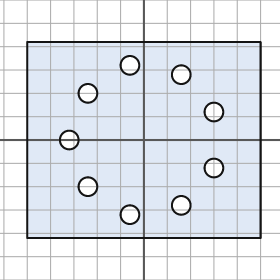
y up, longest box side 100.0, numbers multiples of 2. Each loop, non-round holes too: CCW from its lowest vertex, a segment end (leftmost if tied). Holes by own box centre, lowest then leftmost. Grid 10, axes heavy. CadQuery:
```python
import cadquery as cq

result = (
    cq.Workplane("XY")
    .moveTo(-50.0, -42.0)
    .lineTo(50.0, -42.0)
    .lineTo(50.0, 42.0)
    .lineTo(-50.0, 42.0)
    .close()
    .moveTo(-6.0, -32.0)
    .circle(4.0)
    .moveTo(16.0, -28.0)
    .circle(4.0)
    .moveTo(-24.0, -20.0)
    .circle(4.0)
    .moveTo(30.0, -12.0)
    .circle(4.0)
    .moveTo(-32.0, 0.0)
    .circle(4.0)
    .moveTo(30.0, 12.0)
    .circle(4.0)
    .moveTo(-24.0, 20.0)
    .circle(4.0)
    .moveTo(16.0, 28.0)
    .circle(4.0)
    .moveTo(-6.0, 32.0)
    .circle(4.0)
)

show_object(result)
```